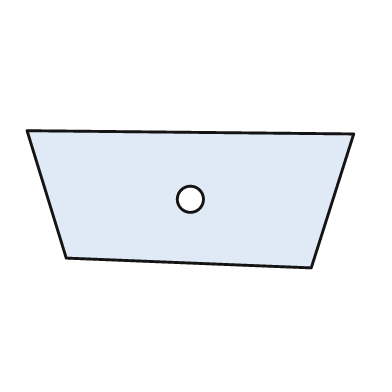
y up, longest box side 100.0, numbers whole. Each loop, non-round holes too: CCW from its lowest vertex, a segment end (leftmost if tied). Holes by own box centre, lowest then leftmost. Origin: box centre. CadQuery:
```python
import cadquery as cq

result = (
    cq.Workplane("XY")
    .moveTo(37.0, -21.0)
    .lineTo(50.0, 20.0)
    .lineTo(-50.0, 21.0)
    .lineTo(-38.0, -18.0)
    .close()
    .moveTo(0.0, 0.0)
    .circle(4.0)
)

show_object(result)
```